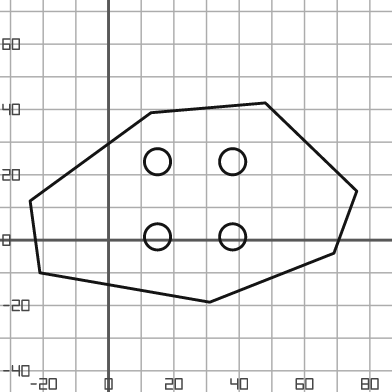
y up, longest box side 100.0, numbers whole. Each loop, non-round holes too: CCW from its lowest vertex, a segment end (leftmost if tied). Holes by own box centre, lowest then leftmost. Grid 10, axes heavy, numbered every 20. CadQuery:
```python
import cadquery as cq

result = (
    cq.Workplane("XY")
    .moveTo(31.0, -19.0)
    .lineTo(69.0, -4.0)
    .lineTo(76.0, 15.0)
    .lineTo(48.0, 42.0)
    .lineTo(13.0, 39.0)
    .lineTo(-24.0, 12.0)
    .lineTo(-21.0, -10.0)
    .close()
    .moveTo(15.0, 1.0)
    .circle(4.0)
    .moveTo(38.0, 1.0)
    .circle(4.0)
    .moveTo(15.0, 24.0)
    .circle(4.0)
    .moveTo(38.0, 24.0)
    .circle(4.0)
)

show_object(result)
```